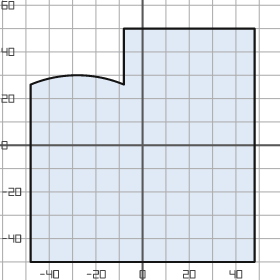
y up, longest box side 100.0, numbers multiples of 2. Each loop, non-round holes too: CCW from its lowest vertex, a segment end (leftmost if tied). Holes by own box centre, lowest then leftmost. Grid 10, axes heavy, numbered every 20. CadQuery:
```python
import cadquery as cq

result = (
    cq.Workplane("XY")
    .moveTo(-48.0, -50.0)
    .lineTo(48.0, -50.0)
    .lineTo(48.0, 50.0)
    .lineTo(-8.0, 50.0)
    .lineTo(-8.0, 26.0)
    .threePointArc((-28.0, 30.0), (-48.0, 26.0))
    .close()
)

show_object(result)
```